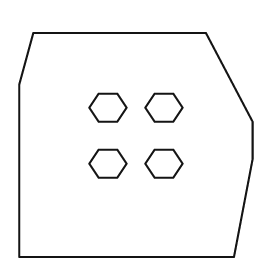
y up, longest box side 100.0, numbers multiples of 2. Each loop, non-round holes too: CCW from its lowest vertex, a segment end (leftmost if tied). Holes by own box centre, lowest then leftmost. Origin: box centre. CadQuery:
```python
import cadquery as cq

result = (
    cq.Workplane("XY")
    .moveTo(-50.0, -48.0)
    .lineTo(42.0, -48.0)
    .lineTo(50.0, -6.0)
    .lineTo(50.0, 10.0)
    .lineTo(30.0, 48.0)
    .lineTo(-44.0, 48.0)
    .lineTo(-50.0, 26.0)
    .close()
    .moveTo(-16.0, -14.0)
    .lineTo(-8.0, -14.0)
    .lineTo(-4.0, -8.0)
    .lineTo(-8.0, -2.0)
    .lineTo(-16.0, -2.0)
    .lineTo(-20.0, -8.0)
    .close()
    .moveTo(8.0, -14.0)
    .lineTo(16.0, -14.0)
    .lineTo(20.0, -8.0)
    .lineTo(16.0, -2.0)
    .lineTo(8.0, -2.0)
    .lineTo(4.0, -8.0)
    .close()
    .moveTo(-16.0, 10.0)
    .lineTo(-8.0, 10.0)
    .lineTo(-4.0, 16.0)
    .lineTo(-8.0, 22.0)
    .lineTo(-16.0, 22.0)
    .lineTo(-20.0, 16.0)
    .close()
    .moveTo(8.0, 10.0)
    .lineTo(16.0, 10.0)
    .lineTo(20.0, 16.0)
    .lineTo(16.0, 22.0)
    .lineTo(8.0, 22.0)
    .lineTo(4.0, 16.0)
    .close()
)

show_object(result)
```